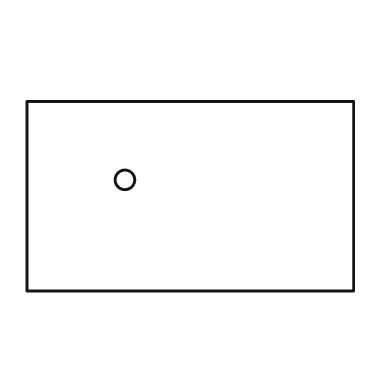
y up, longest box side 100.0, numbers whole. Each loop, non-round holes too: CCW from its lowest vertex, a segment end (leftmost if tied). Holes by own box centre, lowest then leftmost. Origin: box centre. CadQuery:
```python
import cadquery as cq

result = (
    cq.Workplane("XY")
    .moveTo(-50.0, -29.0)
    .lineTo(50.0, -29.0)
    .lineTo(50.0, 29.0)
    .lineTo(-50.0, 29.0)
    .close()
    .moveTo(-20.0, 5.0)
    .circle(3.0)
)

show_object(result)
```